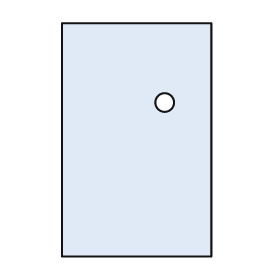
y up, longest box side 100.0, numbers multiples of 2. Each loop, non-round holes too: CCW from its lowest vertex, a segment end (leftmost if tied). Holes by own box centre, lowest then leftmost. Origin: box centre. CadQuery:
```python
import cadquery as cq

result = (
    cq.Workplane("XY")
    .moveTo(-32.0, -50.0)
    .lineTo(32.0, -50.0)
    .lineTo(32.0, 50.0)
    .lineTo(-32.0, 50.0)
    .close()
    .moveTo(12.0, 16.0)
    .circle(4.0)
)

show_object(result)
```